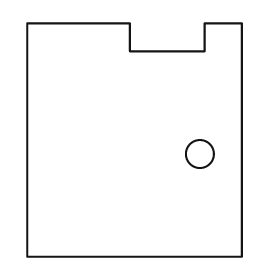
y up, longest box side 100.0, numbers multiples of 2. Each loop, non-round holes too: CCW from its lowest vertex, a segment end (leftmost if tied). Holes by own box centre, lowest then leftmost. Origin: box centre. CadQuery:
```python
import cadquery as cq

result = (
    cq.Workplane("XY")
    .moveTo(-46.0, -50.0)
    .lineTo(46.0, -50.0)
    .lineTo(46.0, 50.0)
    .lineTo(30.0, 50.0)
    .lineTo(30.0, 38.0)
    .lineTo(-2.0, 38.0)
    .lineTo(-2.0, 50.0)
    .lineTo(-46.0, 50.0)
    .close()
    .moveTo(28.0, -6.0)
    .circle(6.0)
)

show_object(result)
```